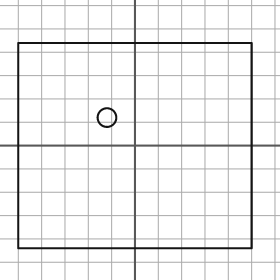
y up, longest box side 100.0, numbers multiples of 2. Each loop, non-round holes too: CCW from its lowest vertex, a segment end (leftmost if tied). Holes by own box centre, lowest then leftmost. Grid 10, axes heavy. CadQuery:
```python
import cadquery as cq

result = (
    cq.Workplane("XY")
    .moveTo(-50.0, -44.0)
    .lineTo(50.0, -44.0)
    .lineTo(50.0, 44.0)
    .lineTo(-50.0, 44.0)
    .close()
    .moveTo(-12.0, 12.0)
    .circle(4.0)
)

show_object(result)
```